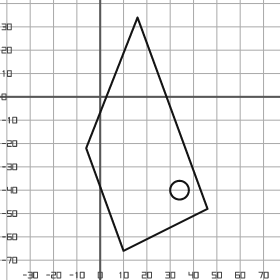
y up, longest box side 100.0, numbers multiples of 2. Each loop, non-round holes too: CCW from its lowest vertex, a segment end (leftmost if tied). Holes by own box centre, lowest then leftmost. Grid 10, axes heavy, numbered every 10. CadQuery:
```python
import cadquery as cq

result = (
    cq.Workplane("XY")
    .moveTo(10.0, -66.0)
    .lineTo(46.0, -48.0)
    .lineTo(16.0, 34.0)
    .lineTo(-6.0, -22.0)
    .close()
    .moveTo(34.0, -40.0)
    .circle(4.0)
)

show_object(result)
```